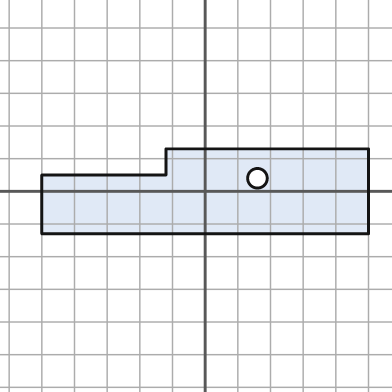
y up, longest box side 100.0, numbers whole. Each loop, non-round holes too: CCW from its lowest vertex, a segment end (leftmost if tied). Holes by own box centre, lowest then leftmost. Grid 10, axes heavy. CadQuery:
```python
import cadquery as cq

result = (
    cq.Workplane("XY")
    .moveTo(-50.0, -13.0)
    .lineTo(50.0, -13.0)
    .lineTo(50.0, 13.0)
    .lineTo(-12.0, 13.0)
    .lineTo(-12.0, 5.0)
    .lineTo(-50.0, 5.0)
    .close()
    .moveTo(16.0, 4.0)
    .circle(3.0)
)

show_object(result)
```